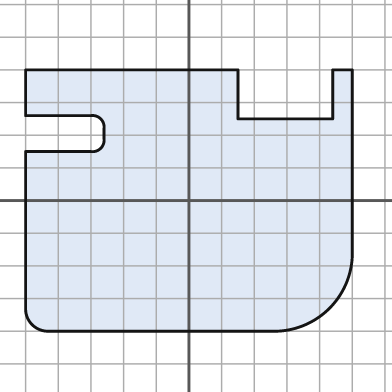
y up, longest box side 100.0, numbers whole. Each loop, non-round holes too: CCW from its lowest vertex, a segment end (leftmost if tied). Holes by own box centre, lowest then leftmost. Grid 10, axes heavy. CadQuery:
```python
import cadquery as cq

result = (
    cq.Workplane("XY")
    .moveTo(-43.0, -40.0)
    .lineTo(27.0, -40.0)
    .threePointArc((43.0, -33.0), (50.0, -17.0))
    .lineTo(50.0, 40.0)
    .lineTo(44.0, 40.0)
    .lineTo(44.0, 25.0)
    .lineTo(15.0, 25.0)
    .lineTo(15.0, 40.0)
    .lineTo(-50.0, 40.0)
    .lineTo(-50.0, 26.0)
    .lineTo(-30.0, 26.0)
    .threePointArc((-27.0, 25.0), (-26.0, 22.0))
    .lineTo(-26.0, 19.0)
    .threePointArc((-27.0, 16.0), (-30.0, 15.0))
    .lineTo(-50.0, 15.0)
    .lineTo(-50.0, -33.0)
    .threePointArc((-48.0, -38.0), (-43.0, -40.0))
    .close()
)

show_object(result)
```